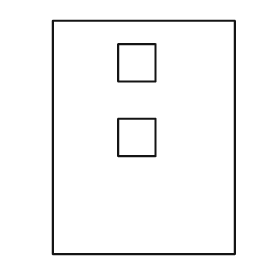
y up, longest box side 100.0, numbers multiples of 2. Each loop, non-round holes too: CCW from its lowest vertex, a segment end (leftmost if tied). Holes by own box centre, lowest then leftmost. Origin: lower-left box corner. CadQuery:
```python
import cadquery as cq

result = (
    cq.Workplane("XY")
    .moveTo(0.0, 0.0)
    .lineTo(78.0, 0.0)
    .lineTo(78.0, 100.0)
    .lineTo(0.0, 100.0)
    .close()
    .moveTo(28.0, 42.0)
    .lineTo(44.0, 42.0)
    .lineTo(44.0, 58.0)
    .lineTo(28.0, 58.0)
    .close()
    .moveTo(28.0, 74.0)
    .lineTo(44.0, 74.0)
    .lineTo(44.0, 90.0)
    .lineTo(28.0, 90.0)
    .close()
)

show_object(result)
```